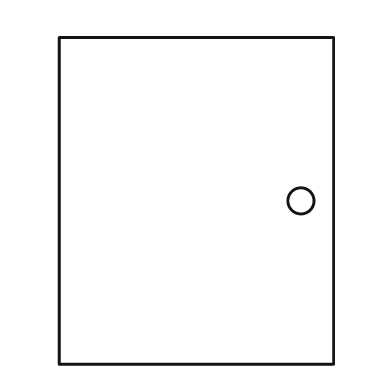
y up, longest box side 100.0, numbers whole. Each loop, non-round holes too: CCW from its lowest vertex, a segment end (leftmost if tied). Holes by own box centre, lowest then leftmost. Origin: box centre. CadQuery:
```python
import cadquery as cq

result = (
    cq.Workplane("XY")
    .moveTo(-42.0, -50.0)
    .lineTo(42.0, -50.0)
    .lineTo(42.0, 50.0)
    .lineTo(-42.0, 50.0)
    .close()
    .moveTo(32.0, 0.0)
    .circle(4.0)
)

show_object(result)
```